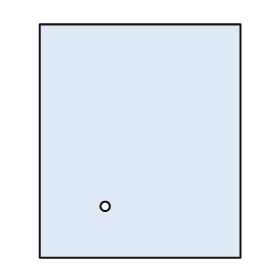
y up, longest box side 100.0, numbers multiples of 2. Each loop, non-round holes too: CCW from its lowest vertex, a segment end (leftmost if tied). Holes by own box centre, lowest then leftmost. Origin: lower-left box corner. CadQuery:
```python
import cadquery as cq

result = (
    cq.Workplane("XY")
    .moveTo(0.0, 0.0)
    .lineTo(86.0, 0.0)
    .lineTo(86.0, 100.0)
    .lineTo(0.0, 100.0)
    .close()
    .moveTo(28.0, 22.0)
    .circle(2.0)
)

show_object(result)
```